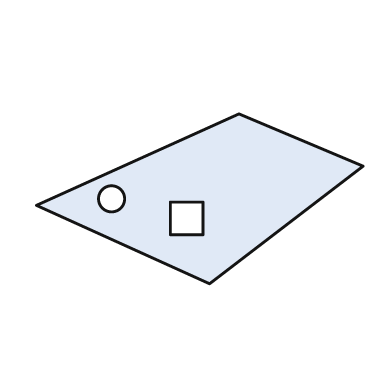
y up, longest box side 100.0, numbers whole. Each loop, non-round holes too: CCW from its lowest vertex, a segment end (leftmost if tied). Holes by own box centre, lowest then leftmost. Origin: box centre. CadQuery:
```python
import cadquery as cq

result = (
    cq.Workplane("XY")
    .moveTo(3.0, -26.0)
    .lineTo(50.0, 10.0)
    .lineTo(12.0, 26.0)
    .lineTo(-50.0, -2.0)
    .close()
    .moveTo(-9.0, -11.0)
    .lineTo(1.0, -11.0)
    .lineTo(1.0, -1.0)
    .lineTo(-9.0, -1.0)
    .close()
    .moveTo(-27.0, 0.0)
    .circle(4.0)
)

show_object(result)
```